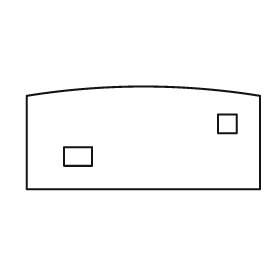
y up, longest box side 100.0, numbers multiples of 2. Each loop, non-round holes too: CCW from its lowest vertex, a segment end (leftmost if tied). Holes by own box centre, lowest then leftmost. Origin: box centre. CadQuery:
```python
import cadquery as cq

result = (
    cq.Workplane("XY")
    .moveTo(-50.0, -22.0)
    .lineTo(50.0, -22.0)
    .lineTo(50.0, 18.0)
    .threePointArc((0.0, 22.0), (-50.0, 18.0))
    .close()
    .moveTo(-34.0, -12.0)
    .lineTo(-22.0, -12.0)
    .lineTo(-22.0, -4.0)
    .lineTo(-34.0, -4.0)
    .close()
    .moveTo(32.0, 2.0)
    .lineTo(40.0, 2.0)
    .lineTo(40.0, 10.0)
    .lineTo(32.0, 10.0)
    .close()
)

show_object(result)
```